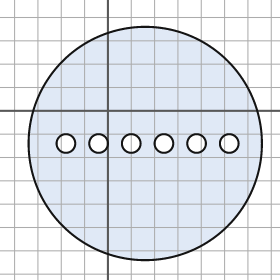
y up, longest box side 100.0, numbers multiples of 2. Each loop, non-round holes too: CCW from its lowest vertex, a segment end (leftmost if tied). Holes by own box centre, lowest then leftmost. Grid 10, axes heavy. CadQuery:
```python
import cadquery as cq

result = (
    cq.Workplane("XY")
    .moveTo(16.0, -14.0)
    .circle(50.0)
    .moveTo(-18.0, -14.0)
    .circle(4.0)
    .moveTo(-4.0, -14.0)
    .circle(4.0)
    .moveTo(10.0, -14.0)
    .circle(4.0)
    .moveTo(24.0, -14.0)
    .circle(4.0)
    .moveTo(38.0, -14.0)
    .circle(4.0)
    .moveTo(52.0, -14.0)
    .circle(4.0)
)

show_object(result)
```